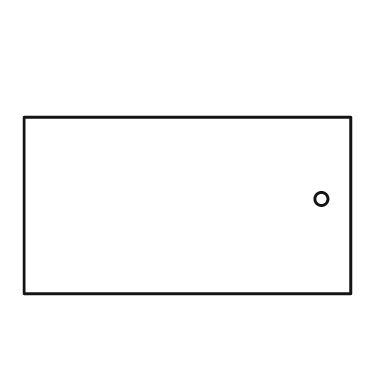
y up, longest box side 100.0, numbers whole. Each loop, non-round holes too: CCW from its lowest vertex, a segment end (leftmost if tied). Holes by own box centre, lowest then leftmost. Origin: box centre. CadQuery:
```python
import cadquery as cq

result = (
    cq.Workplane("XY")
    .moveTo(-50.0, -27.0)
    .lineTo(50.0, -27.0)
    .lineTo(50.0, 27.0)
    .lineTo(-50.0, 27.0)
    .close()
    .moveTo(41.0, 2.0)
    .circle(2.0)
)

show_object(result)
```